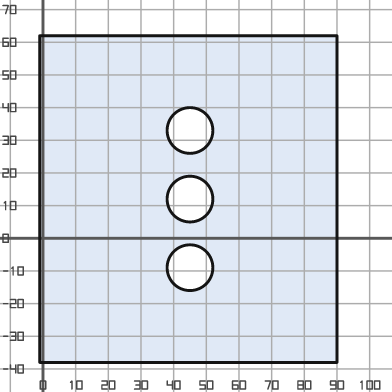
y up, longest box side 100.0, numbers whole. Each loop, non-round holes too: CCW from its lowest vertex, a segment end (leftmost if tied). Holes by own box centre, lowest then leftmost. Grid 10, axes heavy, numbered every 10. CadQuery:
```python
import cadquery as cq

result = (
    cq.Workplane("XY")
    .moveTo(-1.0, -38.0)
    .lineTo(90.0, -38.0)
    .lineTo(90.0, 62.0)
    .lineTo(-1.0, 62.0)
    .close()
    .moveTo(45.0, -9.0)
    .circle(7.0)
    .moveTo(45.0, 12.0)
    .circle(7.0)
    .moveTo(45.0, 33.0)
    .circle(7.0)
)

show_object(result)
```